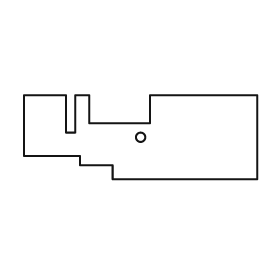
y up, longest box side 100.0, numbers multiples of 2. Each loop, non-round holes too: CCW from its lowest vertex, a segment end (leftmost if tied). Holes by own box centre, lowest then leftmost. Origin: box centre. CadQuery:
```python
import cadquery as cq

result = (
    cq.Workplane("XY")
    .moveTo(-12.0, -18.0)
    .lineTo(50.0, -18.0)
    .lineTo(50.0, 18.0)
    .lineTo(4.0, 18.0)
    .lineTo(4.0, 6.0)
    .lineTo(-22.0, 6.0)
    .lineTo(-22.0, 18.0)
    .lineTo(-28.0, 18.0)
    .lineTo(-28.0, 2.0)
    .lineTo(-32.0, 2.0)
    .lineTo(-32.0, 18.0)
    .lineTo(-50.0, 18.0)
    .lineTo(-50.0, -8.0)
    .lineTo(-26.0, -8.0)
    .lineTo(-26.0, -12.0)
    .lineTo(-12.0, -12.0)
    .close()
    .moveTo(0.0, 0.0)
    .circle(2.0)
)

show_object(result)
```